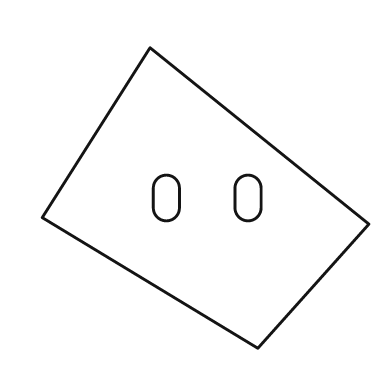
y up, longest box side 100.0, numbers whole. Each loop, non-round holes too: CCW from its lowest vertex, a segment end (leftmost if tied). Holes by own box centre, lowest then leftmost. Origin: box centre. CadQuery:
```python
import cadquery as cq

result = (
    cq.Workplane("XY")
    .moveTo(16.0, -46.0)
    .lineTo(50.0, -8.0)
    .lineTo(-17.0, 46.0)
    .lineTo(-50.0, -6.0)
    .close()
    .moveTo(-16.0, -3.0)
    .threePointArc((-12.0, -7.0), (-8.0, -3.0))
    .lineTo(-8.0, 3.0)
    .threePointArc((-12.0, 7.0), (-16.0, 3.0))
    .close()
    .moveTo(9.0, -3.0)
    .threePointArc((13.0, -7.0), (17.0, -3.0))
    .lineTo(17.0, 3.0)
    .threePointArc((13.0, 7.0), (9.0, 3.0))
    .close()
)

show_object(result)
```